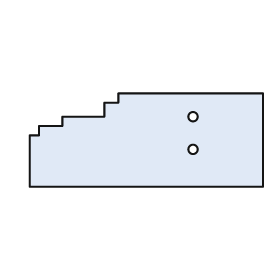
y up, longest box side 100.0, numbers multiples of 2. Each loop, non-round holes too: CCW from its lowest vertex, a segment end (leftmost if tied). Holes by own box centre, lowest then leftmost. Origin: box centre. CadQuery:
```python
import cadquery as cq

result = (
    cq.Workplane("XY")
    .moveTo(-50.0, -20.0)
    .lineTo(50.0, -20.0)
    .lineTo(50.0, 20.0)
    .lineTo(-12.0, 20.0)
    .lineTo(-12.0, 16.0)
    .lineTo(-18.0, 16.0)
    .lineTo(-18.0, 10.0)
    .lineTo(-36.0, 10.0)
    .lineTo(-36.0, 6.0)
    .lineTo(-46.0, 6.0)
    .lineTo(-46.0, 2.0)
    .lineTo(-50.0, 2.0)
    .close()
    .moveTo(20.0, -4.0)
    .circle(2.0)
    .moveTo(20.0, 10.0)
    .circle(2.0)
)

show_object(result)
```